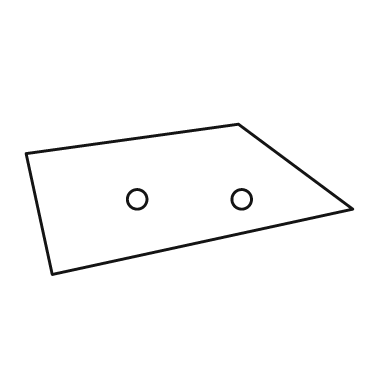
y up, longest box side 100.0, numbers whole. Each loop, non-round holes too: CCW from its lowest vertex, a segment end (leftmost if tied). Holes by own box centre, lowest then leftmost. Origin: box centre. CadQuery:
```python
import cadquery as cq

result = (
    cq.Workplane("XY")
    .moveTo(-42.0, -23.0)
    .lineTo(50.0, -3.0)
    .lineTo(15.0, 23.0)
    .lineTo(-50.0, 14.0)
    .close()
    .moveTo(-16.0, 0.0)
    .circle(3.0)
    .moveTo(16.0, 0.0)
    .circle(3.0)
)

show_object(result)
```